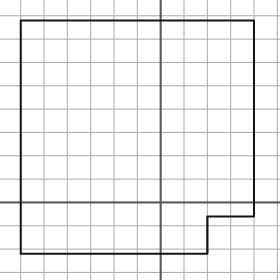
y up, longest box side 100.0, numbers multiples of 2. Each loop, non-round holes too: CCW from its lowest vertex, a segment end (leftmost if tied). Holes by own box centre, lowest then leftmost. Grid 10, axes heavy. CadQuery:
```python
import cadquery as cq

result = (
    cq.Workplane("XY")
    .moveTo(-60.0, -22.0)
    .lineTo(20.0, -22.0)
    .lineTo(20.0, -6.0)
    .lineTo(40.0, -6.0)
    .lineTo(40.0, 78.0)
    .lineTo(-60.0, 78.0)
    .close()
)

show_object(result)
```